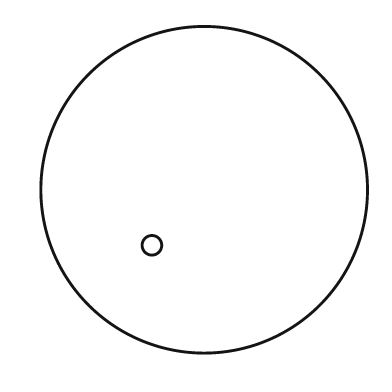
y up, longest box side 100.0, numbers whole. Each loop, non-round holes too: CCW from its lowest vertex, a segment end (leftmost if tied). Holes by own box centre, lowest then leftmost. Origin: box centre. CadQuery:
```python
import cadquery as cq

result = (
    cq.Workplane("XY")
    .moveTo(0.0, 0.0)
    .circle(50.0)
    .moveTo(-16.0, -17.0)
    .circle(3.0)
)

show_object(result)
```